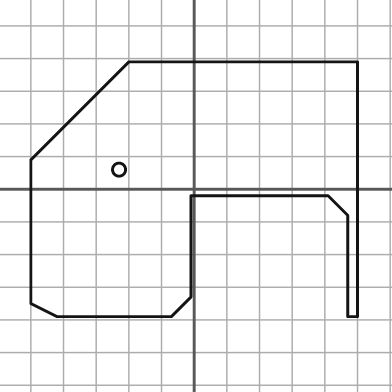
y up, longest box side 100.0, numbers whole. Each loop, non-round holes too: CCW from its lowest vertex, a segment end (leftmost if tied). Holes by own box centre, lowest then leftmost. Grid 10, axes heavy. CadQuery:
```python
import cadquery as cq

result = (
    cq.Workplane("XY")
    .moveTo(-42.0, -39.0)
    .lineTo(-7.0, -39.0)
    .lineTo(-1.0, -33.0)
    .lineTo(-1.0, -2.0)
    .lineTo(41.0, -2.0)
    .lineTo(47.0, -8.0)
    .lineTo(47.0, -39.0)
    .lineTo(50.0, -39.0)
    .lineTo(50.0, 39.0)
    .lineTo(-20.0, 39.0)
    .lineTo(-50.0, 9.0)
    .lineTo(-50.0, -35.0)
    .close()
    .moveTo(-23.0, 6.0)
    .circle(2.0)
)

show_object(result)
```